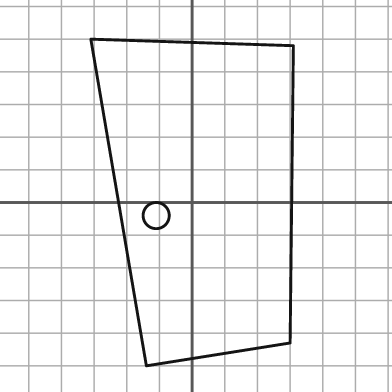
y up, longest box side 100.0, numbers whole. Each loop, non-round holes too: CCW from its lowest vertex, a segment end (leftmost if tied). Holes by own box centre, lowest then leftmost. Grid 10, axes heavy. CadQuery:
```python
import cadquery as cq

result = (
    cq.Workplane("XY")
    .moveTo(-14.0, -50.0)
    .lineTo(30.0, -43.0)
    .lineTo(31.0, 48.0)
    .lineTo(-31.0, 50.0)
    .close()
    .moveTo(-11.0, -4.0)
    .circle(4.0)
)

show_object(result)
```